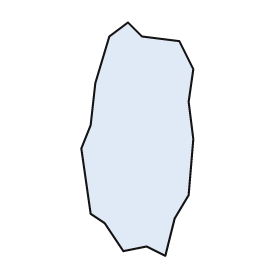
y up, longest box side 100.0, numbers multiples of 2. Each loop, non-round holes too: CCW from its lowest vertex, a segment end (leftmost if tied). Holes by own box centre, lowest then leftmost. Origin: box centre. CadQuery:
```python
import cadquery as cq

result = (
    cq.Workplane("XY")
    .moveTo(12.0, -50.0)
    .lineTo(16.0, -34.0)
    .lineTo(22.0, -24.0)
    .lineTo(24.0, 0.0)
    .lineTo(22.0, 16.0)
    .lineTo(24.0, 30.0)
    .lineTo(18.0, 42.0)
    .lineTo(2.0, 44.0)
    .lineTo(-4.0, 50.0)
    .lineTo(-12.0, 44.0)
    .lineTo(-18.0, 24.0)
    .lineTo(-20.0, 6.0)
    .lineTo(-24.0, -4.0)
    .lineTo(-20.0, -32.0)
    .lineTo(-14.0, -36.0)
    .lineTo(-6.0, -48.0)
    .lineTo(4.0, -46.0)
    .close()
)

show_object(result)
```